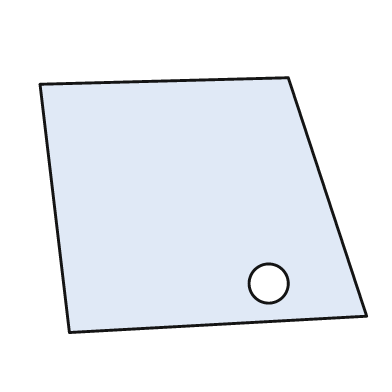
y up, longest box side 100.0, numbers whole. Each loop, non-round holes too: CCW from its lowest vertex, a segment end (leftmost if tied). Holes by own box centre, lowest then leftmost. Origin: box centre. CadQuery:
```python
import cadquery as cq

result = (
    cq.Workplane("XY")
    .moveTo(-41.0, -39.0)
    .lineTo(50.0, -34.0)
    .lineTo(26.0, 39.0)
    .lineTo(-50.0, 37.0)
    .close()
    .moveTo(20.0, -24.0)
    .circle(6.0)
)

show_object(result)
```